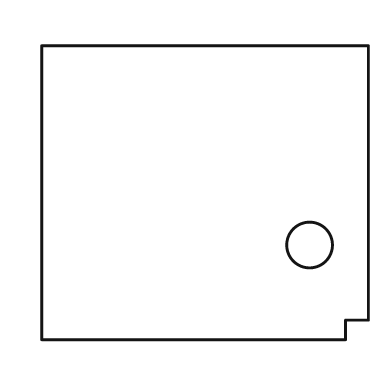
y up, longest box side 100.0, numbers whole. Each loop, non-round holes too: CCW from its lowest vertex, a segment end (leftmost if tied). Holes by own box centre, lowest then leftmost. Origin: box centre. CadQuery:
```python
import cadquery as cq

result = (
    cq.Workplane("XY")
    .moveTo(-50.0, -45.0)
    .lineTo(43.0, -45.0)
    .lineTo(43.0, -39.0)
    .lineTo(50.0, -39.0)
    .lineTo(50.0, 45.0)
    .lineTo(-50.0, 45.0)
    .close()
    .moveTo(32.0, -16.0)
    .circle(7.0)
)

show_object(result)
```